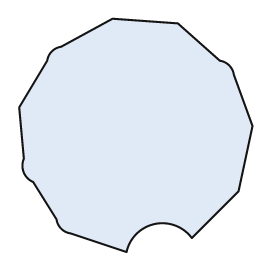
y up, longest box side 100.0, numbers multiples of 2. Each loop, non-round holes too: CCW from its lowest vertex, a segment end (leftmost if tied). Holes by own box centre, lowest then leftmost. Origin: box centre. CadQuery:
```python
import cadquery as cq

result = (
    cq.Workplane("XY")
    .moveTo(-4.0, -50.0)
    .threePointArc((8.0, -38.0), (24.0, -44.0))
    .lineTo(44.0, -24.0)
    .lineTo(50.0, 4.0)
    .lineTo(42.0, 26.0)
    .threePointArc((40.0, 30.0), (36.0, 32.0))
    .lineTo(18.0, 48.0)
    .lineTo(-10.0, 50.0)
    .lineTo(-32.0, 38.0)
    .threePointArc((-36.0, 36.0), (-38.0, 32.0))
    .lineTo(-50.0, 12.0)
    .lineTo(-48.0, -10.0)
    .threePointArc((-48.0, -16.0), (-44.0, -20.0))
    .lineTo(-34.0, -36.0)
    .threePointArc((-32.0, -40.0), (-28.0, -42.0))
    .close()
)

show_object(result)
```